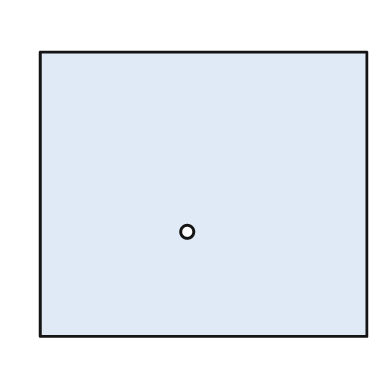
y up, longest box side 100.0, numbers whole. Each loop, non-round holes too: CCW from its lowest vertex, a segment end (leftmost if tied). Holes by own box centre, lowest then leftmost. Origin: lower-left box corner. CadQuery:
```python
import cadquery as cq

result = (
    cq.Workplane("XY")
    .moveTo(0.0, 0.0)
    .lineTo(100.0, 0.0)
    .lineTo(100.0, 87.0)
    .lineTo(0.0, 87.0)
    .close()
    .moveTo(45.0, 32.0)
    .circle(2.0)
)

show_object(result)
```